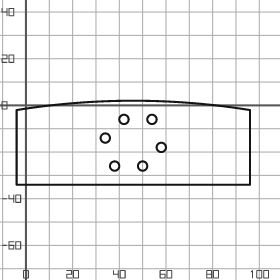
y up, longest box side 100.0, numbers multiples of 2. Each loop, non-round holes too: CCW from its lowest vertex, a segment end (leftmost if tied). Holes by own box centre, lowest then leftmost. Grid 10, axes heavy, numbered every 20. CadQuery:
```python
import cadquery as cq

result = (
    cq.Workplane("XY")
    .moveTo(-4.0, -34.0)
    .lineTo(96.0, -34.0)
    .lineTo(96.0, -2.0)
    .threePointArc((46.0, 2.0), (-4.0, -2.0))
    .close()
    .moveTo(38.0, -26.0)
    .circle(2.0)
    .moveTo(50.0, -26.0)
    .circle(2.0)
    .moveTo(58.0, -18.0)
    .circle(2.0)
    .moveTo(34.0, -14.0)
    .circle(2.0)
    .moveTo(42.0, -6.0)
    .circle(2.0)
    .moveTo(54.0, -6.0)
    .circle(2.0)
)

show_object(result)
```